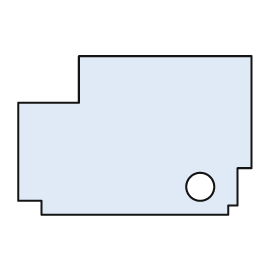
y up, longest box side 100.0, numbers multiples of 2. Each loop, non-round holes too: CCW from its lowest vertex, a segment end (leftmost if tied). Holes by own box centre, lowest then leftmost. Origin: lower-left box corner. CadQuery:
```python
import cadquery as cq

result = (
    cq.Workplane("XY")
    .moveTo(10.0, 0.0)
    .lineTo(90.0, 0.0)
    .lineTo(90.0, 4.0)
    .lineTo(94.0, 4.0)
    .lineTo(94.0, 20.0)
    .lineTo(100.0, 20.0)
    .lineTo(100.0, 68.0)
    .lineTo(26.0, 68.0)
    .lineTo(26.0, 48.0)
    .lineTo(0.0, 48.0)
    .lineTo(0.0, 6.0)
    .lineTo(10.0, 6.0)
    .close()
    .moveTo(78.0, 12.0)
    .circle(6.0)
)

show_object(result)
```